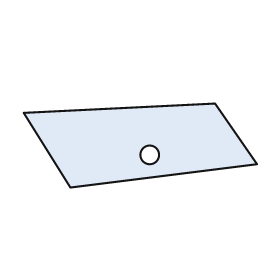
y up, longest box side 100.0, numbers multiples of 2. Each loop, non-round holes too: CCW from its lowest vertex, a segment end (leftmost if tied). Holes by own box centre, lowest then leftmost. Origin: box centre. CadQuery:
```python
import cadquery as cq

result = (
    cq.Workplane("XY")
    .moveTo(-30.0, -18.0)
    .lineTo(50.0, -8.0)
    .lineTo(32.0, 18.0)
    .lineTo(-50.0, 14.0)
    .close()
    .moveTo(4.0, -4.0)
    .circle(4.0)
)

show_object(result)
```